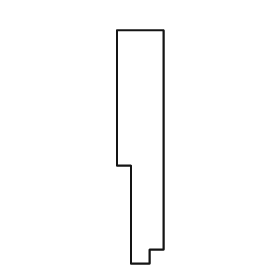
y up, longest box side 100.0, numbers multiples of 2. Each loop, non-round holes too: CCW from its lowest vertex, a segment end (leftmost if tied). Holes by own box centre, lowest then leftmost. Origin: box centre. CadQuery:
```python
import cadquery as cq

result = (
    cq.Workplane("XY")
    .moveTo(-4.0, -50.0)
    .lineTo(4.0, -50.0)
    .lineTo(4.0, -44.0)
    .lineTo(10.0, -44.0)
    .lineTo(10.0, 50.0)
    .lineTo(-10.0, 50.0)
    .lineTo(-10.0, -8.0)
    .lineTo(-4.0, -8.0)
    .close()
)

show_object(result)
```